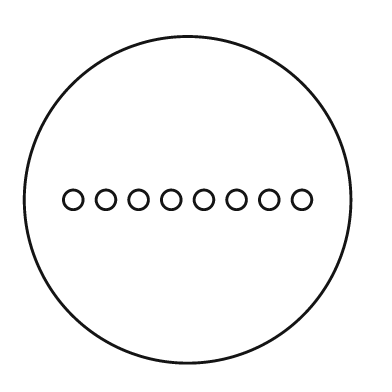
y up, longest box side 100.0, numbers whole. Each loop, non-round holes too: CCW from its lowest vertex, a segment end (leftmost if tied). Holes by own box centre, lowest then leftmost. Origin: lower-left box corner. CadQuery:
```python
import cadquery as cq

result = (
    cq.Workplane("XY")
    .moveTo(50.0, 50.0)
    .circle(50.0)
    .moveTo(15.0, 50.0)
    .circle(3.0)
    .moveTo(25.0, 50.0)
    .circle(3.0)
    .moveTo(35.0, 50.0)
    .circle(3.0)
    .moveTo(45.0, 50.0)
    .circle(3.0)
    .moveTo(55.0, 50.0)
    .circle(3.0)
    .moveTo(65.0, 50.0)
    .circle(3.0)
    .moveTo(75.0, 50.0)
    .circle(3.0)
    .moveTo(85.0, 50.0)
    .circle(3.0)
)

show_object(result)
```